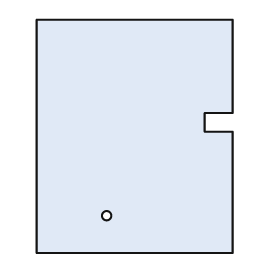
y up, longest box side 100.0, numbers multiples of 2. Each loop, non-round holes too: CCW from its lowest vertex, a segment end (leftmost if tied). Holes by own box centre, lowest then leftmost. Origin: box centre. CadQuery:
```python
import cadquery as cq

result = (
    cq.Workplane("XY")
    .moveTo(-42.0, -50.0)
    .lineTo(42.0, -50.0)
    .lineTo(42.0, 2.0)
    .lineTo(30.0, 2.0)
    .lineTo(30.0, 10.0)
    .lineTo(42.0, 10.0)
    .lineTo(42.0, 50.0)
    .lineTo(-42.0, 50.0)
    .close()
    .moveTo(-12.0, -34.0)
    .circle(2.0)
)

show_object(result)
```